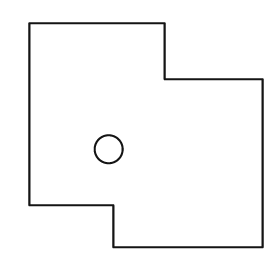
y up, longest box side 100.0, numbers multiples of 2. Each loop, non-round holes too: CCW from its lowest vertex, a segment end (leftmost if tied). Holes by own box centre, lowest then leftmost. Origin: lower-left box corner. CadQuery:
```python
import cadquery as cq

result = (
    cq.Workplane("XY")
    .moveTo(36.0, 0.0)
    .lineTo(100.0, 0.0)
    .lineTo(100.0, 72.0)
    .lineTo(58.0, 72.0)
    .lineTo(58.0, 96.0)
    .lineTo(0.0, 96.0)
    .lineTo(0.0, 18.0)
    .lineTo(36.0, 18.0)
    .close()
    .moveTo(34.0, 42.0)
    .circle(6.0)
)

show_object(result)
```